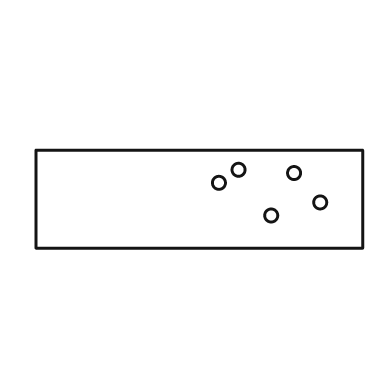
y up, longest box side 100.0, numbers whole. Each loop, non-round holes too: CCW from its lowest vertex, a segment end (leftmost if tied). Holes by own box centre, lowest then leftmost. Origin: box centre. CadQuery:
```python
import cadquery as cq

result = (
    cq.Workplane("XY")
    .moveTo(-50.0, -15.0)
    .lineTo(50.0, -15.0)
    .lineTo(50.0, 15.0)
    .lineTo(-50.0, 15.0)
    .close()
    .moveTo(22.0, -5.0)
    .circle(2.0)
    .moveTo(37.0, -1.0)
    .circle(2.0)
    .moveTo(6.0, 5.0)
    .circle(2.0)
    .moveTo(29.0, 8.0)
    .circle(2.0)
    .moveTo(12.0, 9.0)
    .circle(2.0)
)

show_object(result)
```